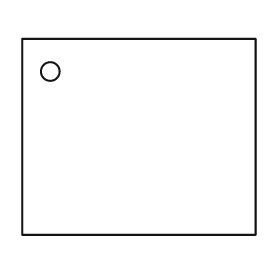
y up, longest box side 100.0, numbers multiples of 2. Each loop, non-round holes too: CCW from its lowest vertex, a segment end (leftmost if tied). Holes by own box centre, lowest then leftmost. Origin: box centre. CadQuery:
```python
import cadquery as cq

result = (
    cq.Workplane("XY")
    .moveTo(-50.0, -42.0)
    .lineTo(50.0, -42.0)
    .lineTo(50.0, 42.0)
    .lineTo(-50.0, 42.0)
    .close()
    .moveTo(-38.0, 28.0)
    .circle(4.0)
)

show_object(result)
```